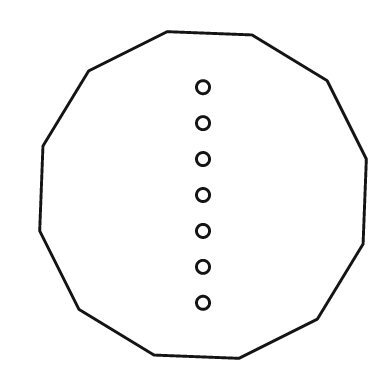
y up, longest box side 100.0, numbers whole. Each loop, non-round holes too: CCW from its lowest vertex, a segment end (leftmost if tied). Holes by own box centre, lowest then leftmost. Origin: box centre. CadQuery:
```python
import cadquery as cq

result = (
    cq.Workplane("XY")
    .moveTo(11.0, -50.0)
    .lineTo(35.0, -38.0)
    .lineTo(49.0, -15.0)
    .lineTo(50.0, 11.0)
    .lineTo(38.0, 35.0)
    .lineTo(15.0, 49.0)
    .lineTo(-11.0, 50.0)
    .lineTo(-35.0, 38.0)
    .lineTo(-49.0, 15.0)
    .lineTo(-50.0, -11.0)
    .lineTo(-38.0, -35.0)
    .lineTo(-15.0, -49.0)
    .close()
    .moveTo(0.0, -33.0)
    .circle(2.0)
    .moveTo(0.0, -22.0)
    .circle(2.0)
    .moveTo(0.0, -11.0)
    .circle(2.0)
    .moveTo(0.0, 0.0)
    .circle(2.0)
    .moveTo(0.0, 11.0)
    .circle(2.0)
    .moveTo(0.0, 22.0)
    .circle(2.0)
    .moveTo(0.0, 33.0)
    .circle(2.0)
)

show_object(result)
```